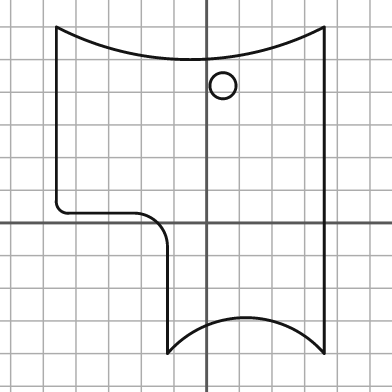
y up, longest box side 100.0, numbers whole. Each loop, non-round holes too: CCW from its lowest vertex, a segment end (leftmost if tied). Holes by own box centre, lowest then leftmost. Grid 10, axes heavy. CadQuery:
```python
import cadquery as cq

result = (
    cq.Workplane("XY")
    .moveTo(-12.0, -40.0)
    .threePointArc((12.0, -29.0), (36.0, -40.0))
    .lineTo(36.0, 60.0)
    .threePointArc((-5.0, 50.0), (-46.0, 60.0))
    .lineTo(-46.0, 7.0)
    .threePointArc((-45.0, 4.0), (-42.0, 3.0))
    .lineTo(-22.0, 3.0)
    .threePointArc((-15.0, 0.0), (-12.0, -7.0))
    .close()
    .moveTo(5.0, 42.0)
    .circle(4.0)
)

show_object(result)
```